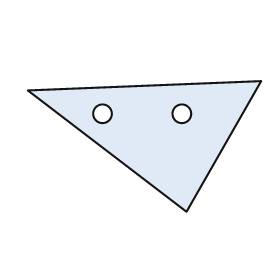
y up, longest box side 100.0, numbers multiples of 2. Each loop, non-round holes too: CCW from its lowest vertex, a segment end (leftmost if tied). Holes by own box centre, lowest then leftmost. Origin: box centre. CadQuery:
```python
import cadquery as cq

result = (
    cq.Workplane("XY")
    .moveTo(18.0, -28.0)
    .lineTo(50.0, 28.0)
    .lineTo(-50.0, 24.0)
    .close()
    .moveTo(-18.0, 14.0)
    .circle(4.0)
    .moveTo(16.0, 14.0)
    .circle(4.0)
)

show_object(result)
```